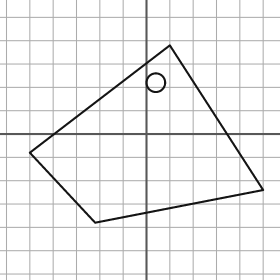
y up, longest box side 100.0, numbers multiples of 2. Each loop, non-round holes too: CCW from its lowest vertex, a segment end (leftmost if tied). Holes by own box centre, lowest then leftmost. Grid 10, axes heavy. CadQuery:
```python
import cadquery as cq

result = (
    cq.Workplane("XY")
    .moveTo(-22.0, -38.0)
    .lineTo(50.0, -24.0)
    .lineTo(10.0, 38.0)
    .lineTo(-50.0, -8.0)
    .close()
    .moveTo(4.0, 22.0)
    .circle(4.0)
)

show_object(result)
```